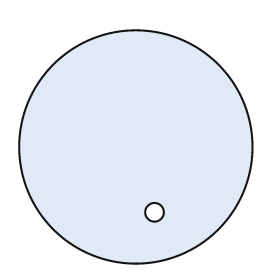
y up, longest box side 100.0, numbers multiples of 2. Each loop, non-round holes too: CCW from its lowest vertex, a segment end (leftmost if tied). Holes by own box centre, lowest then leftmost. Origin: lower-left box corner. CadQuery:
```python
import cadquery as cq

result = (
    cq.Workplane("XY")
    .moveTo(50.0, 50.0)
    .circle(50.0)
    .moveTo(58.0, 22.0)
    .circle(4.0)
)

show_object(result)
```